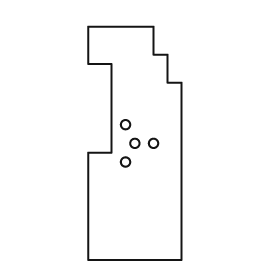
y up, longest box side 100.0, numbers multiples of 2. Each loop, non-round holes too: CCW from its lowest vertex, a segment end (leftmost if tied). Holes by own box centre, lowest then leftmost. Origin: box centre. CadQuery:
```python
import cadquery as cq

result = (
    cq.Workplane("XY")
    .moveTo(-20.0, -50.0)
    .lineTo(20.0, -50.0)
    .lineTo(20.0, 26.0)
    .lineTo(14.0, 26.0)
    .lineTo(14.0, 38.0)
    .lineTo(8.0, 38.0)
    .lineTo(8.0, 50.0)
    .lineTo(-20.0, 50.0)
    .lineTo(-20.0, 34.0)
    .lineTo(-10.0, 34.0)
    .lineTo(-10.0, -4.0)
    .lineTo(-20.0, -4.0)
    .close()
    .moveTo(-4.0, -8.0)
    .circle(2.0)
    .moveTo(0.0, 0.0)
    .circle(2.0)
    .moveTo(8.0, 0.0)
    .circle(2.0)
    .moveTo(-4.0, 8.0)
    .circle(2.0)
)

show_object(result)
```